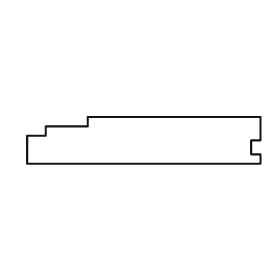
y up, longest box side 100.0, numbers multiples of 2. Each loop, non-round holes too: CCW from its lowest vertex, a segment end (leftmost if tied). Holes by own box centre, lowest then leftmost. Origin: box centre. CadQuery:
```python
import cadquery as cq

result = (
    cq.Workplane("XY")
    .moveTo(-50.0, -10.0)
    .lineTo(50.0, -10.0)
    .lineTo(50.0, -6.0)
    .lineTo(46.0, -6.0)
    .lineTo(46.0, 0.0)
    .lineTo(50.0, 0.0)
    .lineTo(50.0, 10.0)
    .lineTo(-24.0, 10.0)
    .lineTo(-24.0, 6.0)
    .lineTo(-42.0, 6.0)
    .lineTo(-42.0, 2.0)
    .lineTo(-50.0, 2.0)
    .close()
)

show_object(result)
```